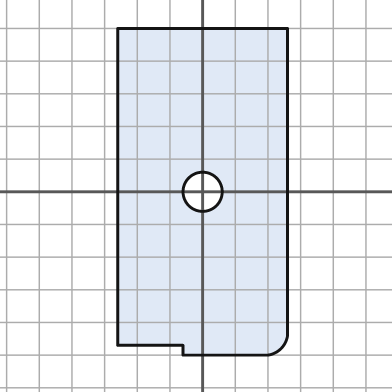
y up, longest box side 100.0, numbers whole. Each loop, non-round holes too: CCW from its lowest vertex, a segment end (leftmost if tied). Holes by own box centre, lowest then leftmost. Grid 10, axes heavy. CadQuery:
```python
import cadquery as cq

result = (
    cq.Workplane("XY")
    .moveTo(-6.0, -50.0)
    .lineTo(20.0, -50.0)
    .threePointArc((24.0, -48.0), (26.0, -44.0))
    .lineTo(26.0, 50.0)
    .lineTo(-26.0, 50.0)
    .lineTo(-26.0, -47.0)
    .lineTo(-6.0, -47.0)
    .close()
    .moveTo(0.0, 0.0)
    .circle(6.0)
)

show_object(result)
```